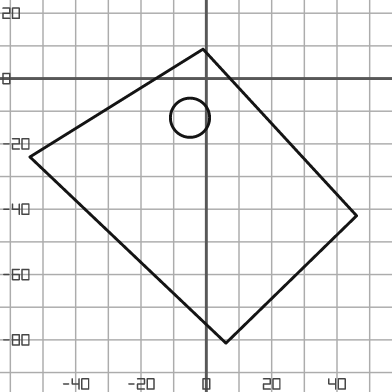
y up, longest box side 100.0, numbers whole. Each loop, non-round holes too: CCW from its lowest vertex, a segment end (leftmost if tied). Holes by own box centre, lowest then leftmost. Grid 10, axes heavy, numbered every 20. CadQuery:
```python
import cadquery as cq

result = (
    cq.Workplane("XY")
    .moveTo(6.0, -81.0)
    .lineTo(46.0, -42.0)
    .lineTo(-1.0, 9.0)
    .lineTo(-54.0, -24.0)
    .close()
    .moveTo(-5.0, -12.0)
    .circle(6.0)
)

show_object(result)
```